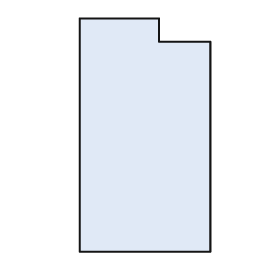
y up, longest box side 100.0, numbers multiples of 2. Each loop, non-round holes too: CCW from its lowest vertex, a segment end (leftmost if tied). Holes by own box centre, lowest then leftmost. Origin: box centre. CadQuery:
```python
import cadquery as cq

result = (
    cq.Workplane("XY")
    .moveTo(-28.0, -50.0)
    .lineTo(28.0, -50.0)
    .lineTo(28.0, 40.0)
    .lineTo(6.0, 40.0)
    .lineTo(6.0, 50.0)
    .lineTo(-28.0, 50.0)
    .close()
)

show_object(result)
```